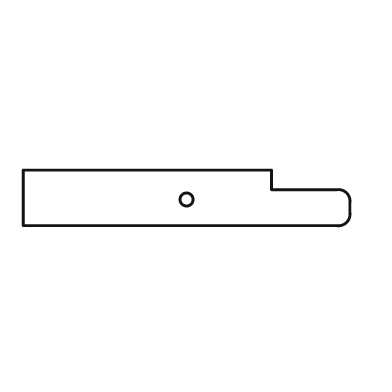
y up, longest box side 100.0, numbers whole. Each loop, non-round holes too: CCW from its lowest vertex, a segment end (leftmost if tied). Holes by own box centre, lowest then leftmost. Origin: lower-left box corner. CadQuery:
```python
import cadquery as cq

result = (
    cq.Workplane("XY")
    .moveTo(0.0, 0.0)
    .lineTo(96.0, 0.0)
    .threePointArc((99.0, 1.0), (100.0, 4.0))
    .lineTo(100.0, 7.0)
    .threePointArc((99.0, 10.0), (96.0, 11.0))
    .lineTo(76.0, 11.0)
    .lineTo(76.0, 17.0)
    .lineTo(0.0, 17.0)
    .close()
    .moveTo(50.0, 8.0)
    .circle(2.0)
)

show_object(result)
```